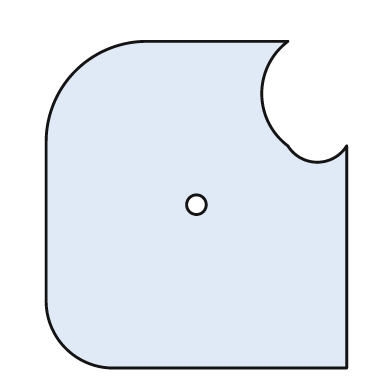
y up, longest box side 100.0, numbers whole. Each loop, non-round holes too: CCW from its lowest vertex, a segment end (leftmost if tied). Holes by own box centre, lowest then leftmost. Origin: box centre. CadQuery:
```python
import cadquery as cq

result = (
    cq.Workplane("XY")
    .moveTo(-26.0, -50.0)
    .lineTo(46.0, -50.0)
    .lineTo(46.0, 18.0)
    .threePointArc((37.0, 13.0), (28.0, 18.0))
    .threePointArc((20.0, 34.0), (28.0, 50.0))
    .lineTo(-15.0, 50.0)
    .threePointArc((-37.0, 41.0), (-46.0, 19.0))
    .lineTo(-46.0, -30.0)
    .threePointArc((-40.0, -44.0), (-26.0, -50.0))
    .close()
    .moveTo(0.0, 0.0)
    .circle(3.0)
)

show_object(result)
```